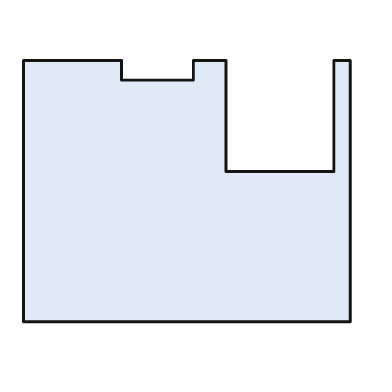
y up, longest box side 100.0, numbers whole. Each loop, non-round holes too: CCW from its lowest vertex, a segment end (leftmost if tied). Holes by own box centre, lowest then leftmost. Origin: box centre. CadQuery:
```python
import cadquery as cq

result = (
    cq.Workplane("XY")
    .moveTo(-50.0, -40.0)
    .lineTo(50.0, -40.0)
    .lineTo(50.0, 40.0)
    .lineTo(45.0, 40.0)
    .lineTo(45.0, 6.0)
    .lineTo(12.0, 6.0)
    .lineTo(12.0, 40.0)
    .lineTo(2.0, 40.0)
    .lineTo(2.0, 34.0)
    .lineTo(-20.0, 34.0)
    .lineTo(-20.0, 40.0)
    .lineTo(-50.0, 40.0)
    .close()
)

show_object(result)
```